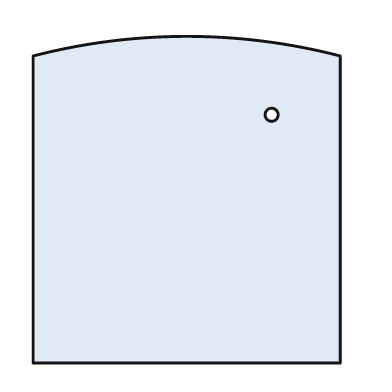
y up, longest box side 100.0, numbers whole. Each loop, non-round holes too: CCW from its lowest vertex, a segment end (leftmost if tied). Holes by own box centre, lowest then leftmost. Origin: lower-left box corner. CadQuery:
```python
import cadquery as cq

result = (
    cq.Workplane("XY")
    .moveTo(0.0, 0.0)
    .lineTo(94.0, 0.0)
    .lineTo(94.0, 94.0)
    .threePointArc((47.0, 100.0), (0.0, 94.0))
    .close()
    .moveTo(73.0, 76.0)
    .circle(2.0)
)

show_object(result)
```